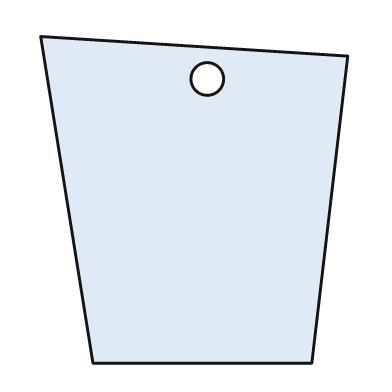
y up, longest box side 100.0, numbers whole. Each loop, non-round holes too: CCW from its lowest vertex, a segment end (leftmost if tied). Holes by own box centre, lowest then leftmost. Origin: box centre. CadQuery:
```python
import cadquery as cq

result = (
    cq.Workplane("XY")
    .moveTo(-31.0, -50.0)
    .lineTo(36.0, -50.0)
    .lineTo(47.0, 44.0)
    .lineTo(-47.0, 50.0)
    .close()
    .moveTo(4.0, 37.0)
    .circle(5.0)
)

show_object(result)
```